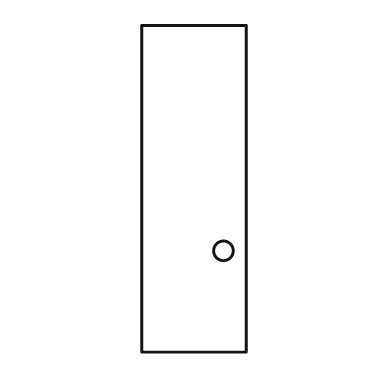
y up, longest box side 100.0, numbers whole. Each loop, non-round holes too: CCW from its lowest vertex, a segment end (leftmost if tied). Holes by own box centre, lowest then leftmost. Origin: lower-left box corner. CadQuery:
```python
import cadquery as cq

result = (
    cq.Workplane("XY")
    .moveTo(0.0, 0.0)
    .lineTo(32.0, 0.0)
    .lineTo(32.0, 100.0)
    .lineTo(0.0, 100.0)
    .close()
    .moveTo(25.0, 31.0)
    .circle(3.0)
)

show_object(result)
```